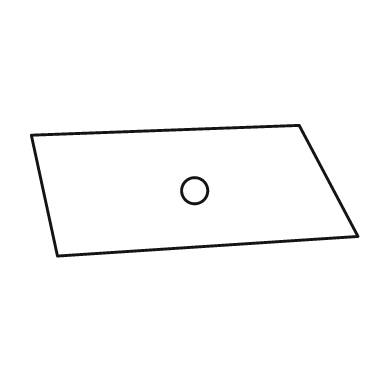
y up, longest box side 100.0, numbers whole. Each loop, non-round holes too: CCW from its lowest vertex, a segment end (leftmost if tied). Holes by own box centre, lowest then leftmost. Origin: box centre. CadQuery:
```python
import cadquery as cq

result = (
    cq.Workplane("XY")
    .moveTo(-42.0, -20.0)
    .lineTo(50.0, -14.0)
    .lineTo(32.0, 20.0)
    .lineTo(-50.0, 17.0)
    .close()
    .moveTo(0.0, 0.0)
    .circle(4.0)
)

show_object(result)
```